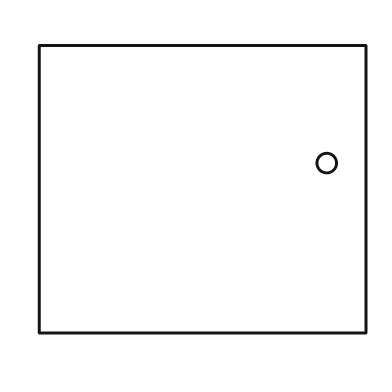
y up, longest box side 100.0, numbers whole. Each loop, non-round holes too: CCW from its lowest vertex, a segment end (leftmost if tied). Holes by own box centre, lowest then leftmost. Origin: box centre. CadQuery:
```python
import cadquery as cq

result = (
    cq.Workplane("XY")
    .moveTo(-50.0, -44.0)
    .lineTo(50.0, -44.0)
    .lineTo(50.0, 44.0)
    .lineTo(-50.0, 44.0)
    .close()
    .moveTo(38.0, 8.0)
    .circle(3.0)
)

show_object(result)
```